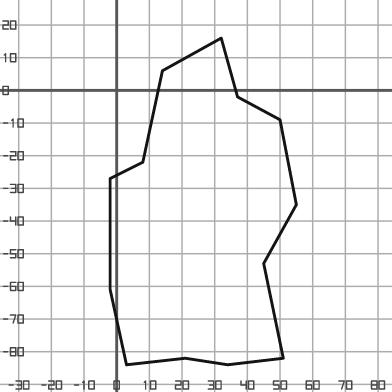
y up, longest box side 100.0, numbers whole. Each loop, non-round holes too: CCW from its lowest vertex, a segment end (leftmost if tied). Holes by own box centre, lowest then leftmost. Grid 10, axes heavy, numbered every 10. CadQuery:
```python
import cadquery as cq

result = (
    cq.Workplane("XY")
    .moveTo(3.0, -84.0)
    .lineTo(21.0, -82.0)
    .lineTo(34.0, -84.0)
    .lineTo(51.0, -82.0)
    .lineTo(45.0, -53.0)
    .lineTo(55.0, -35.0)
    .lineTo(50.0, -9.0)
    .lineTo(37.0, -2.0)
    .lineTo(32.0, 16.0)
    .lineTo(14.0, 6.0)
    .lineTo(8.0, -22.0)
    .lineTo(-2.0, -27.0)
    .lineTo(-2.0, -61.0)
    .close()
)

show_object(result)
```